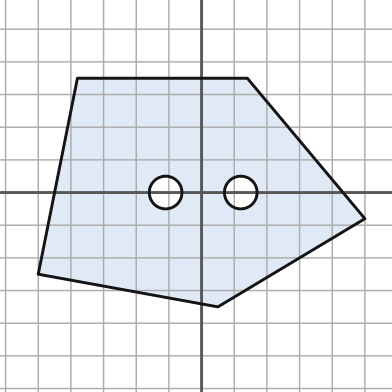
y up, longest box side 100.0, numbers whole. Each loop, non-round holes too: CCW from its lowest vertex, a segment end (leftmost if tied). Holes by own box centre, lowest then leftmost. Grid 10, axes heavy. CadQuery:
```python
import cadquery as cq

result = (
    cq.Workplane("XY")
    .moveTo(5.0, -35.0)
    .lineTo(50.0, -8.0)
    .lineTo(14.0, 35.0)
    .lineTo(-38.0, 35.0)
    .lineTo(-50.0, -25.0)
    .close()
    .moveTo(-11.0, 0.0)
    .circle(5.0)
    .moveTo(12.0, 0.0)
    .circle(5.0)
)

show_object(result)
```